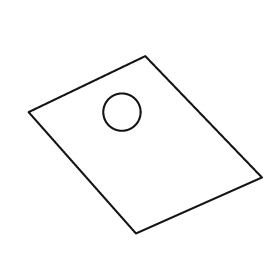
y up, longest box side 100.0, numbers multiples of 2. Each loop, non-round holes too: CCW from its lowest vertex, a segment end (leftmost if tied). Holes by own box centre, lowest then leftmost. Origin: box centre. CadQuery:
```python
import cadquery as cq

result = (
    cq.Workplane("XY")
    .moveTo(-4.0, -38.0)
    .lineTo(50.0, -14.0)
    .lineTo(0.0, 38.0)
    .lineTo(-50.0, 14.0)
    .close()
    .moveTo(-10.0, 14.0)
    .circle(8.0)
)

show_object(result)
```